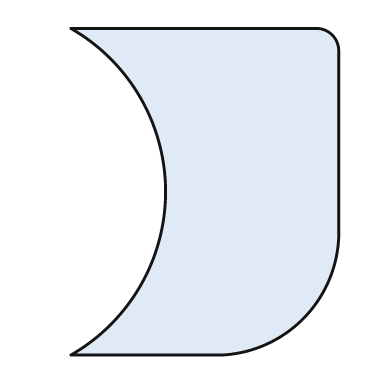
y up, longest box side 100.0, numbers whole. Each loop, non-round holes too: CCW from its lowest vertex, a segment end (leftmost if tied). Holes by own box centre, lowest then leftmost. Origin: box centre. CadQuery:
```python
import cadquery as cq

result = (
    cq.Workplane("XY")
    .moveTo(-41.0, -50.0)
    .lineTo(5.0, -50.0)
    .threePointArc((30.0, -39.0), (41.0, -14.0))
    .lineTo(41.0, 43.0)
    .threePointArc((39.0, 48.0), (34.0, 50.0))
    .lineTo(-41.0, 50.0)
    .threePointArc((-12.0, 0.0), (-41.0, -50.0))
    .close()
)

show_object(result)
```